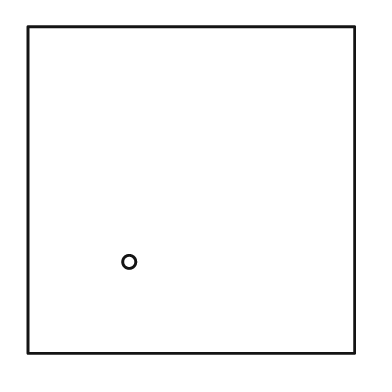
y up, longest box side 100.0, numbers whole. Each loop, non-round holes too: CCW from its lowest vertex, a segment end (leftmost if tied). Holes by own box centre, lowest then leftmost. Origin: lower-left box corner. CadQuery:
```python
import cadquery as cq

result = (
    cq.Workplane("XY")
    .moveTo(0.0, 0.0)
    .lineTo(100.0, 0.0)
    .lineTo(100.0, 100.0)
    .lineTo(0.0, 100.0)
    .close()
    .moveTo(31.0, 28.0)
    .circle(2.0)
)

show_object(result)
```